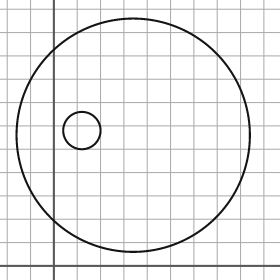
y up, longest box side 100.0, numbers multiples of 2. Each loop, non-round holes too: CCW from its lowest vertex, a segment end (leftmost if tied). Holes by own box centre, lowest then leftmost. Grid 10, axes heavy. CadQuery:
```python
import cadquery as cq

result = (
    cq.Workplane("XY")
    .moveTo(34.0, 56.0)
    .circle(50.0)
    .moveTo(12.0, 58.0)
    .circle(8.0)
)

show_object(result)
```